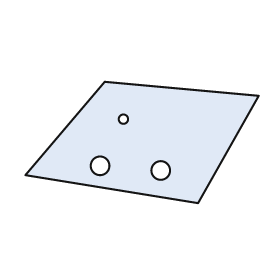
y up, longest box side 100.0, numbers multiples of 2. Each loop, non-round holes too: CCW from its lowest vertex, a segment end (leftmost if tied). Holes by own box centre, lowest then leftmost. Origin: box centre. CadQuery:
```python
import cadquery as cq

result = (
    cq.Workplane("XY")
    .moveTo(24.0, -26.0)
    .lineTo(50.0, 20.0)
    .lineTo(-16.0, 26.0)
    .lineTo(-50.0, -14.0)
    .close()
    .moveTo(8.0, -12.0)
    .circle(4.0)
    .moveTo(-18.0, -10.0)
    .circle(4.0)
    .moveTo(-8.0, 10.0)
    .circle(2.0)
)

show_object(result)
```